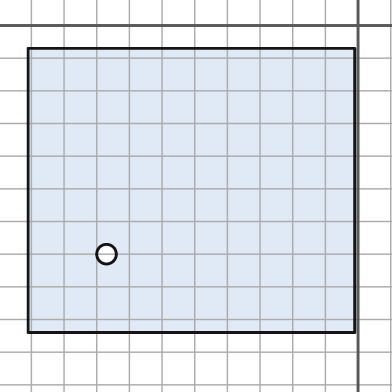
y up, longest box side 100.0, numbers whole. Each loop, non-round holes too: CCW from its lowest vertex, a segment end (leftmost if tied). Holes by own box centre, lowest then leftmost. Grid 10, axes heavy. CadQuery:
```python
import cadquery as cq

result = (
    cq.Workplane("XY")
    .moveTo(-101.0, -94.0)
    .lineTo(-1.0, -94.0)
    .lineTo(-1.0, -7.0)
    .lineTo(-101.0, -7.0)
    .close()
    .moveTo(-77.0, -70.0)
    .circle(3.0)
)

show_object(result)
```